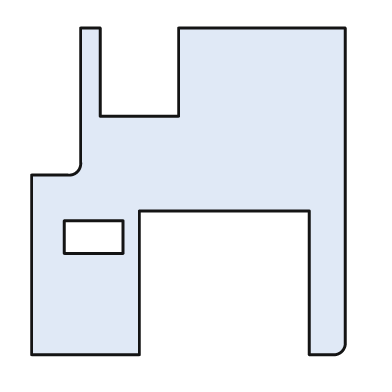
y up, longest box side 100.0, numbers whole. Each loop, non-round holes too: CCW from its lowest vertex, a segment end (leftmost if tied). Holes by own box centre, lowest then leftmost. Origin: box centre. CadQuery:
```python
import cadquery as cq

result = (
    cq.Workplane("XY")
    .moveTo(-48.0, -50.0)
    .lineTo(-15.0, -50.0)
    .lineTo(-15.0, -6.0)
    .lineTo(37.0, -6.0)
    .lineTo(37.0, -50.0)
    .lineTo(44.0, -50.0)
    .threePointArc((47.0, -49.0), (48.0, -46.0))
    .lineTo(48.0, 50.0)
    .lineTo(-3.0, 50.0)
    .lineTo(-3.0, 23.0)
    .lineTo(-27.0, 23.0)
    .lineTo(-27.0, 50.0)
    .lineTo(-33.0, 50.0)
    .lineTo(-33.0, 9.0)
    .threePointArc((-34.0, 6.0), (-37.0, 5.0))
    .lineTo(-48.0, 5.0)
    .close()
    .moveTo(-38.0, -19.0)
    .lineTo(-20.0, -19.0)
    .lineTo(-20.0, -9.0)
    .lineTo(-38.0, -9.0)
    .close()
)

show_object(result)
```